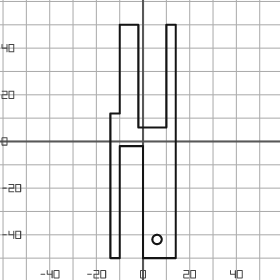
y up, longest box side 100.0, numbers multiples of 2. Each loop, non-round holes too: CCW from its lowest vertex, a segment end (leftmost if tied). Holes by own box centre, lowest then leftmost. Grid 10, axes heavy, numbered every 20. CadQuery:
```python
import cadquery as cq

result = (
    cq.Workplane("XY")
    .moveTo(-14.0, -50.0)
    .lineTo(-10.0, -50.0)
    .lineTo(-10.0, -2.0)
    .lineTo(0.0, -2.0)
    .lineTo(0.0, -50.0)
    .lineTo(14.0, -50.0)
    .lineTo(14.0, 50.0)
    .lineTo(10.0, 50.0)
    .lineTo(10.0, 6.0)
    .lineTo(-2.0, 6.0)
    .lineTo(-2.0, 50.0)
    .lineTo(-10.0, 50.0)
    .lineTo(-10.0, 12.0)
    .lineTo(-14.0, 12.0)
    .close()
    .moveTo(6.0, -42.0)
    .circle(2.0)
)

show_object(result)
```